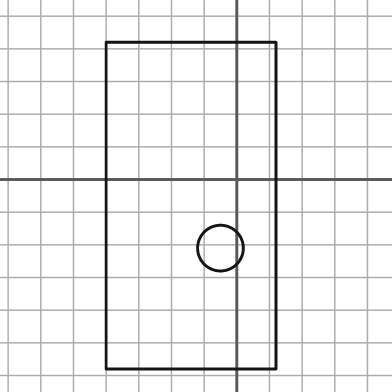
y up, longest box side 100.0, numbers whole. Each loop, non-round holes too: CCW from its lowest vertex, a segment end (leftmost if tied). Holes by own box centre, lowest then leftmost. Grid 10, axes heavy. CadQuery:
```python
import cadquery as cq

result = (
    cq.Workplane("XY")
    .moveTo(-40.0, -58.0)
    .lineTo(12.0, -58.0)
    .lineTo(12.0, 42.0)
    .lineTo(-40.0, 42.0)
    .close()
    .moveTo(-5.0, -21.0)
    .circle(7.0)
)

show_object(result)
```